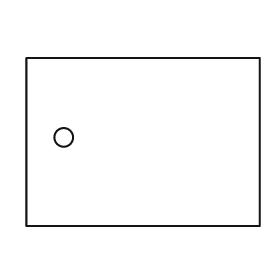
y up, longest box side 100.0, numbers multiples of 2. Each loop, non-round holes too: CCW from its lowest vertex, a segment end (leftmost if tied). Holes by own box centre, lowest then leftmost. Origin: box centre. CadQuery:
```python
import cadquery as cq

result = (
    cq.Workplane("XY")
    .moveTo(-50.0, -36.0)
    .lineTo(50.0, -36.0)
    .lineTo(50.0, 36.0)
    .lineTo(-50.0, 36.0)
    .close()
    .moveTo(-34.0, 2.0)
    .circle(4.0)
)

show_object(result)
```